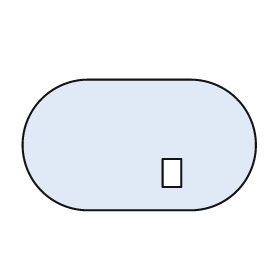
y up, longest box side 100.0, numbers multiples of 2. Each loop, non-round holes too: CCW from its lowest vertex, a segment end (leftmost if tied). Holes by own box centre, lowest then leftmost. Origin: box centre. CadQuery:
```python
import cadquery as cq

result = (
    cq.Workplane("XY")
    .moveTo(-22.0, -28.0)
    .lineTo(22.0, -28.0)
    .threePointArc((50.0, 0.0), (22.0, 28.0))
    .lineTo(-22.0, 28.0)
    .threePointArc((-50.0, 0.0), (-22.0, -28.0))
    .close()
    .moveTo(10.0, -18.0)
    .lineTo(18.0, -18.0)
    .lineTo(18.0, -6.0)
    .lineTo(10.0, -6.0)
    .close()
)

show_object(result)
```